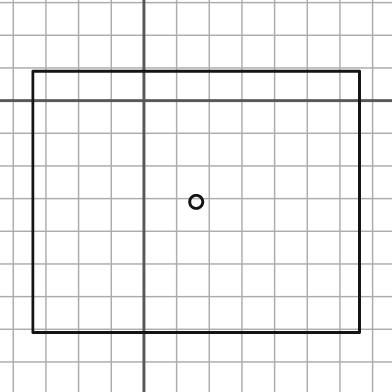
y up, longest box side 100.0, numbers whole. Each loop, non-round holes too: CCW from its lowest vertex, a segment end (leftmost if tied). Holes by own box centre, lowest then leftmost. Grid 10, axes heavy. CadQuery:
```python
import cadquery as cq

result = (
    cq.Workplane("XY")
    .moveTo(-34.0, -71.0)
    .lineTo(66.0, -71.0)
    .lineTo(66.0, 9.0)
    .lineTo(-34.0, 9.0)
    .close()
    .moveTo(16.0, -31.0)
    .circle(2.0)
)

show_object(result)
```